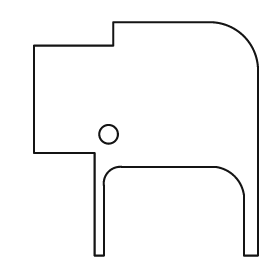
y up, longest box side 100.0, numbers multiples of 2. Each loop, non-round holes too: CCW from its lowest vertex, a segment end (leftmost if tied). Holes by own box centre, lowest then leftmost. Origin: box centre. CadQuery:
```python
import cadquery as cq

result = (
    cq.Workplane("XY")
    .moveTo(-22.0, -50.0)
    .lineTo(-18.0, -50.0)
    .lineTo(-18.0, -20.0)
    .threePointArc((-16.0, -14.0), (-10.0, -12.0))
    .lineTo(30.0, -12.0)
    .threePointArc((38.0, -16.0), (42.0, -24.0))
    .lineTo(42.0, -50.0)
    .lineTo(48.0, -50.0)
    .lineTo(48.0, 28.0)
    .threePointArc((42.0, 44.0), (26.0, 50.0))
    .lineTo(-14.0, 50.0)
    .lineTo(-14.0, 40.0)
    .lineTo(-48.0, 40.0)
    .lineTo(-48.0, -6.0)
    .lineTo(-22.0, -6.0)
    .close()
    .moveTo(-16.0, 2.0)
    .circle(4.0)
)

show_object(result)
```